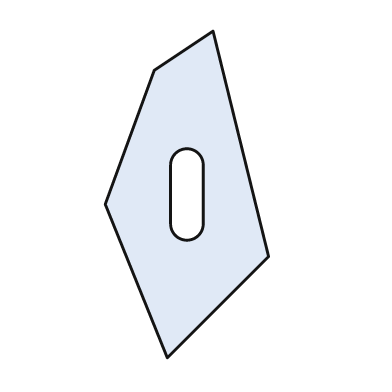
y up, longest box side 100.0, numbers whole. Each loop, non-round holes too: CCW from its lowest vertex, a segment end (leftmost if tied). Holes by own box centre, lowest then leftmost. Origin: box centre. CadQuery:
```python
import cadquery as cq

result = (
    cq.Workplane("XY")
    .moveTo(-6.0, -50.0)
    .lineTo(25.0, -19.0)
    .lineTo(8.0, 50.0)
    .lineTo(-10.0, 38.0)
    .lineTo(-25.0, -3.0)
    .close()
    .moveTo(-5.0, -9.0)
    .threePointArc((0.0, -14.0), (5.0, -9.0))
    .lineTo(5.0, 9.0)
    .threePointArc((0.0, 14.0), (-5.0, 9.0))
    .close()
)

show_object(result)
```